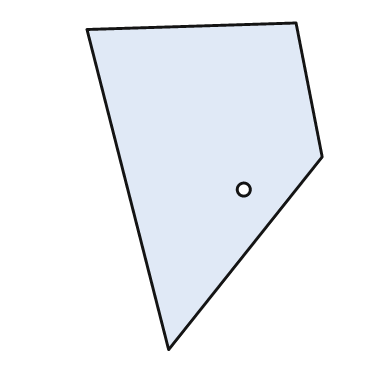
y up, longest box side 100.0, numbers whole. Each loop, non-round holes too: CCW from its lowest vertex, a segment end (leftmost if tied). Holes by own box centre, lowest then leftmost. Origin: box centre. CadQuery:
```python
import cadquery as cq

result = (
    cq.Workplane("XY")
    .moveTo(-11.0, -50.0)
    .lineTo(36.0, 9.0)
    .lineTo(28.0, 50.0)
    .lineTo(-36.0, 48.0)
    .close()
    .moveTo(12.0, -1.0)
    .circle(2.0)
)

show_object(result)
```